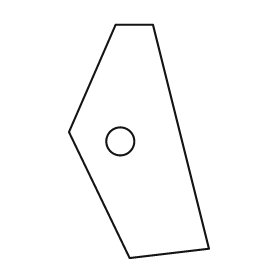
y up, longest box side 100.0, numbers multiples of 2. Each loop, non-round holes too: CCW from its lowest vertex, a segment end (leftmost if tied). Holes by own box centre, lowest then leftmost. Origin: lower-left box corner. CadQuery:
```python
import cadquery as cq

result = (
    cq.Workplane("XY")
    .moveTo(26.0, 0.0)
    .lineTo(60.0, 4.0)
    .lineTo(36.0, 100.0)
    .lineTo(20.0, 100.0)
    .lineTo(0.0, 54.0)
    .close()
    .moveTo(22.0, 50.0)
    .circle(6.0)
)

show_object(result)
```